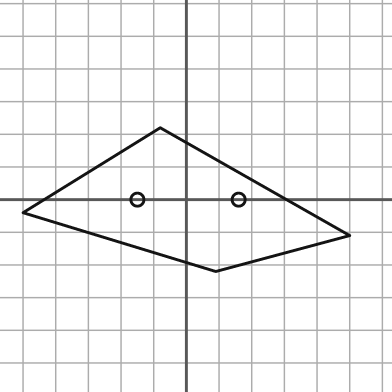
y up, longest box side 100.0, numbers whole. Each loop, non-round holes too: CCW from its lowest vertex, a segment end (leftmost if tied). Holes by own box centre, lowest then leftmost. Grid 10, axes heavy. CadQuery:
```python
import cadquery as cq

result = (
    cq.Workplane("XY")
    .moveTo(9.0, -22.0)
    .lineTo(50.0, -11.0)
    .lineTo(-8.0, 22.0)
    .lineTo(-50.0, -4.0)
    .close()
    .moveTo(-15.0, 0.0)
    .circle(2.0)
    .moveTo(16.0, 0.0)
    .circle(2.0)
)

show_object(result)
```